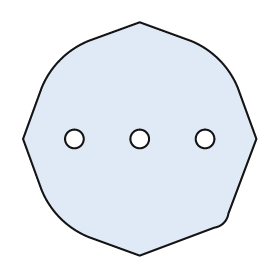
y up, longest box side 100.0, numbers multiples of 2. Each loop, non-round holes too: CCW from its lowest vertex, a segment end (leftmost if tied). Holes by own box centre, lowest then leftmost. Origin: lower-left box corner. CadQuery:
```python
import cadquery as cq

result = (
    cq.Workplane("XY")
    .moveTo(50.0, 0.0)
    .lineTo(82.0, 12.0)
    .threePointArc((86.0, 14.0), (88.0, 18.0))
    .lineTo(100.0, 50.0)
    .lineTo(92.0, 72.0)
    .threePointArc((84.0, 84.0), (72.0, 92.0))
    .lineTo(50.0, 100.0)
    .lineTo(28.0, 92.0)
    .threePointArc((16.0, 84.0), (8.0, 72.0))
    .lineTo(0.0, 50.0)
    .lineTo(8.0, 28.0)
    .threePointArc((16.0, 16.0), (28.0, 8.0))
    .close()
    .moveTo(22.0, 50.0)
    .circle(4.0)
    .moveTo(50.0, 50.0)
    .circle(4.0)
    .moveTo(78.0, 50.0)
    .circle(4.0)
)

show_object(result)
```